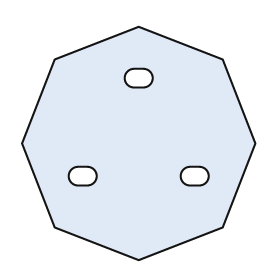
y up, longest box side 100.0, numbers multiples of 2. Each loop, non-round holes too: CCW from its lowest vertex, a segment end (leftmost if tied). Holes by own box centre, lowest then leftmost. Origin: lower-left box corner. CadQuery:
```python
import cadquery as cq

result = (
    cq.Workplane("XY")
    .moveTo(50.0, 0.0)
    .lineTo(86.0, 14.0)
    .lineTo(100.0, 50.0)
    .lineTo(86.0, 86.0)
    .lineTo(50.0, 100.0)
    .lineTo(14.0, 86.0)
    .lineTo(0.0, 50.0)
    .lineTo(14.0, 14.0)
    .close()
    .moveTo(24.0, 32.0)
    .lineTo(28.0, 32.0)
    .threePointArc((32.0, 36.0), (28.0, 40.0))
    .lineTo(24.0, 40.0)
    .threePointArc((20.0, 36.0), (24.0, 32.0))
    .close()
    .moveTo(72.0, 32.0)
    .lineTo(76.0, 32.0)
    .threePointArc((80.0, 36.0), (76.0, 40.0))
    .lineTo(72.0, 40.0)
    .threePointArc((68.0, 36.0), (72.0, 32.0))
    .close()
    .moveTo(48.0, 74.0)
    .lineTo(52.0, 74.0)
    .threePointArc((56.0, 78.0), (52.0, 82.0))
    .lineTo(48.0, 82.0)
    .threePointArc((44.0, 78.0), (48.0, 74.0))
    .close()
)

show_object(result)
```